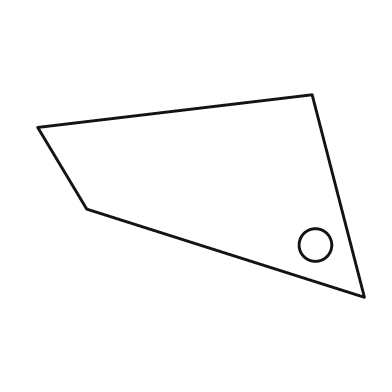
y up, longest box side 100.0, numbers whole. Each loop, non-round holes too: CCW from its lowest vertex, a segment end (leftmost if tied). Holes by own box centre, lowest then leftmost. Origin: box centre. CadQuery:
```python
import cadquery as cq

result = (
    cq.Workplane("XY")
    .moveTo(50.0, -31.0)
    .lineTo(34.0, 31.0)
    .lineTo(-50.0, 21.0)
    .lineTo(-35.0, -4.0)
    .close()
    .moveTo(35.0, -15.0)
    .circle(5.0)
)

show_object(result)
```